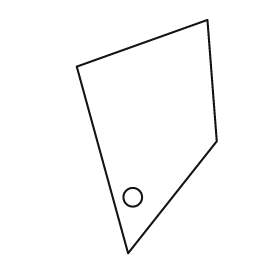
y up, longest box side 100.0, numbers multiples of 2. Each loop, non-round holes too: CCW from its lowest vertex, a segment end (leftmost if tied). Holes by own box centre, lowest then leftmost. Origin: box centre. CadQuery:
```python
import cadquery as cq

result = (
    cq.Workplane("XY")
    .moveTo(-8.0, -50.0)
    .lineTo(30.0, -2.0)
    .lineTo(26.0, 50.0)
    .lineTo(-30.0, 30.0)
    .close()
    .moveTo(-6.0, -26.0)
    .circle(4.0)
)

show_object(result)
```